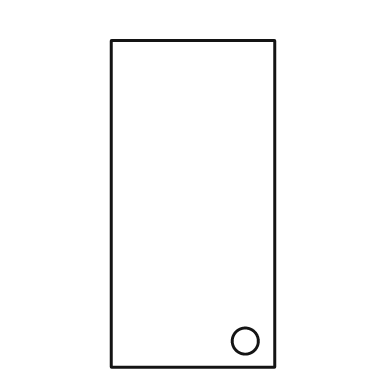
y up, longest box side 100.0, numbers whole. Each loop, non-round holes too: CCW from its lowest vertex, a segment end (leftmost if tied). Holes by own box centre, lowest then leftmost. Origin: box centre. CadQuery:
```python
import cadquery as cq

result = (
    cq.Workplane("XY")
    .moveTo(-25.0, -50.0)
    .lineTo(25.0, -50.0)
    .lineTo(25.0, 50.0)
    .lineTo(-25.0, 50.0)
    .close()
    .moveTo(16.0, -42.0)
    .circle(4.0)
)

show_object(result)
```